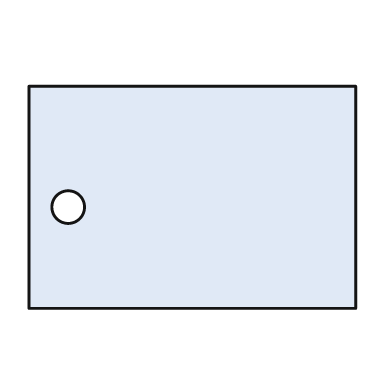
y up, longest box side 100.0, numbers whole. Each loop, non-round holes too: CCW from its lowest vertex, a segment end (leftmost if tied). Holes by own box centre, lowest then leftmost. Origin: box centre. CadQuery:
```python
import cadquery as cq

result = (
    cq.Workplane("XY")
    .moveTo(-50.0, -34.0)
    .lineTo(50.0, -34.0)
    .lineTo(50.0, 34.0)
    .lineTo(-50.0, 34.0)
    .close()
    .moveTo(-38.0, -3.0)
    .circle(5.0)
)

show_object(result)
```